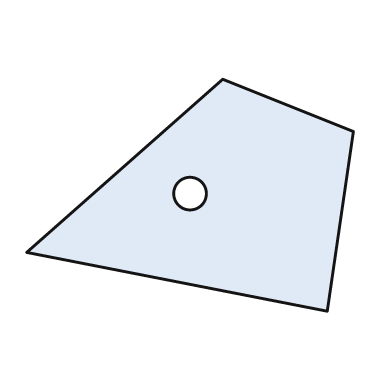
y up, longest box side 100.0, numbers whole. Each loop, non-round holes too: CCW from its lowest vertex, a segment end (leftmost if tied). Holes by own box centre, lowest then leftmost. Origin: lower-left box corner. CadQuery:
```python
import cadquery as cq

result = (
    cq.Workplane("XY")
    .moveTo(92.0, 0.0)
    .lineTo(100.0, 55.0)
    .lineTo(60.0, 71.0)
    .lineTo(0.0, 18.0)
    .close()
    .moveTo(50.0, 36.0)
    .circle(5.0)
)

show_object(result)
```